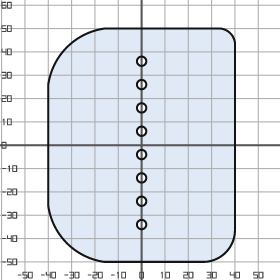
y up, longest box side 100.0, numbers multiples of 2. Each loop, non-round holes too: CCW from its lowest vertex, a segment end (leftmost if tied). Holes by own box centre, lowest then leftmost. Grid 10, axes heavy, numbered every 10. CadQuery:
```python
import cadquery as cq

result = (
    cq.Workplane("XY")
    .moveTo(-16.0, -50.0)
    .lineTo(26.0, -50.0)
    .threePointArc((36.0, -46.0), (40.0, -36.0))
    .lineTo(40.0, 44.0)
    .threePointArc((38.0, 48.0), (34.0, 50.0))
    .lineTo(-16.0, 50.0)
    .threePointArc((-32.0, 42.0), (-40.0, 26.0))
    .lineTo(-40.0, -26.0)
    .threePointArc((-32.0, -42.0), (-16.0, -50.0))
    .close()
    .moveTo(0.0, -34.0)
    .circle(2.0)
    .moveTo(0.0, -24.0)
    .circle(2.0)
    .moveTo(0.0, -14.0)
    .circle(2.0)
    .moveTo(0.0, -4.0)
    .circle(2.0)
    .moveTo(0.0, 6.0)
    .circle(2.0)
    .moveTo(0.0, 16.0)
    .circle(2.0)
    .moveTo(0.0, 26.0)
    .circle(2.0)
    .moveTo(0.0, 36.0)
    .circle(2.0)
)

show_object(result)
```